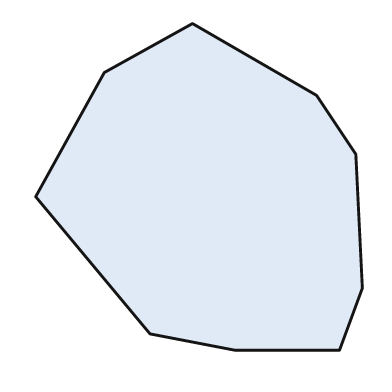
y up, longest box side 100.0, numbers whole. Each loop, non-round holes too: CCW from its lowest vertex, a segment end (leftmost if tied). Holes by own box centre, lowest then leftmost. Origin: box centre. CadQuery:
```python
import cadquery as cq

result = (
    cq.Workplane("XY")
    .moveTo(11.0, -50.0)
    .lineTo(43.0, -50.0)
    .lineTo(50.0, -31.0)
    .lineTo(48.0, 10.0)
    .lineTo(36.0, 28.0)
    .lineTo(-2.0, 50.0)
    .lineTo(-29.0, 35.0)
    .lineTo(-50.0, -3.0)
    .lineTo(-15.0, -45.0)
    .close()
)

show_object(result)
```